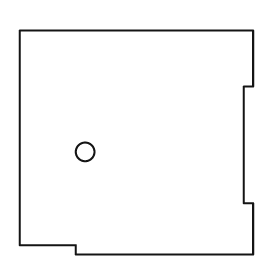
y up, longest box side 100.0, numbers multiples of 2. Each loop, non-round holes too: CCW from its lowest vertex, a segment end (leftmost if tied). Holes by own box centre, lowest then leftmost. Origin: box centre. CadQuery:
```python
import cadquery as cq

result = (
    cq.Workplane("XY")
    .moveTo(-26.0, -48.0)
    .lineTo(50.0, -48.0)
    .lineTo(50.0, -26.0)
    .lineTo(46.0, -26.0)
    .lineTo(46.0, 24.0)
    .lineTo(50.0, 24.0)
    .lineTo(50.0, 48.0)
    .lineTo(-50.0, 48.0)
    .lineTo(-50.0, -44.0)
    .lineTo(-26.0, -44.0)
    .close()
    .moveTo(-22.0, -4.0)
    .circle(4.0)
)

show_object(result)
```